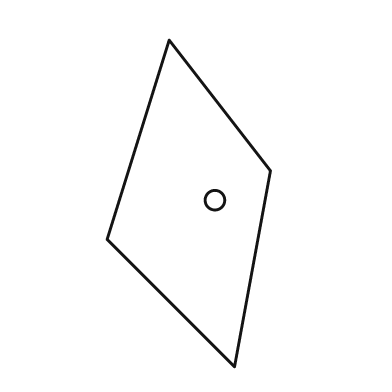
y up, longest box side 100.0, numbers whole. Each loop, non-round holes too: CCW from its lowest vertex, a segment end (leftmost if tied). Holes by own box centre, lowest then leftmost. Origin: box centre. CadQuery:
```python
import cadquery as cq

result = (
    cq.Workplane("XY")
    .moveTo(14.0, -50.0)
    .lineTo(25.0, 10.0)
    .lineTo(-6.0, 50.0)
    .lineTo(-25.0, -11.0)
    .close()
    .moveTo(8.0, 1.0)
    .circle(3.0)
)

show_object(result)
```